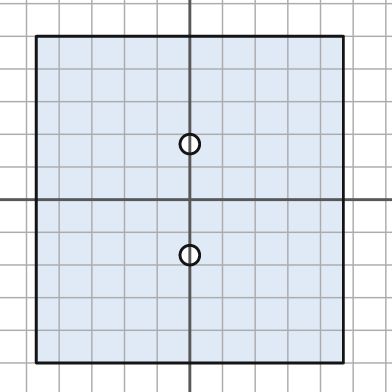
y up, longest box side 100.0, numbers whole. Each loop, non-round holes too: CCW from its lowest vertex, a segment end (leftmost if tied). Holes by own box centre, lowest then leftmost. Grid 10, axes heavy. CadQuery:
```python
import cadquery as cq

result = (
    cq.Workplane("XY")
    .moveTo(-47.0, -50.0)
    .lineTo(47.0, -50.0)
    .lineTo(47.0, 50.0)
    .lineTo(-47.0, 50.0)
    .close()
    .moveTo(0.0, -17.0)
    .circle(3.0)
    .moveTo(0.0, 17.0)
    .circle(3.0)
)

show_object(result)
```